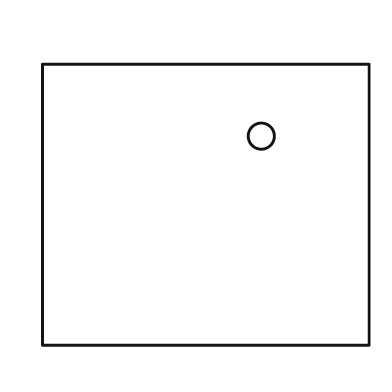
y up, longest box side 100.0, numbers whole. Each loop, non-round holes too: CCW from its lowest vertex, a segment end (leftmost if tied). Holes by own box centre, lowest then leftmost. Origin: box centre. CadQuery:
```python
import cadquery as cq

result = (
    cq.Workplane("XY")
    .moveTo(-50.0, -43.0)
    .lineTo(50.0, -43.0)
    .lineTo(50.0, 43.0)
    .lineTo(-50.0, 43.0)
    .close()
    .moveTo(17.0, 21.0)
    .circle(4.0)
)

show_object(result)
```